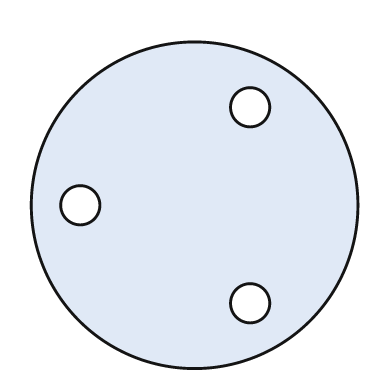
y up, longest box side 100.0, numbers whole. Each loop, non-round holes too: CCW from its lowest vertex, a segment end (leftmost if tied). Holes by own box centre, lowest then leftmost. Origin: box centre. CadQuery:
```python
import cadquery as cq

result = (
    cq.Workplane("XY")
    .moveTo(0.0, 0.0)
    .circle(50.0)
    .moveTo(17.0, -30.0)
    .circle(6.0)
    .moveTo(-35.0, 0.0)
    .circle(6.0)
    .moveTo(17.0, 30.0)
    .circle(6.0)
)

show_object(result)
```